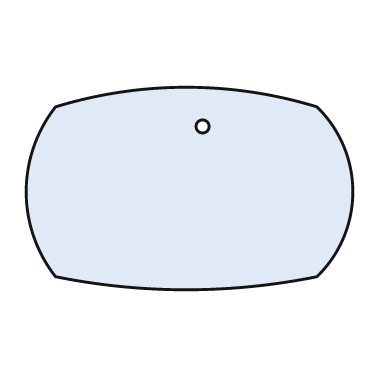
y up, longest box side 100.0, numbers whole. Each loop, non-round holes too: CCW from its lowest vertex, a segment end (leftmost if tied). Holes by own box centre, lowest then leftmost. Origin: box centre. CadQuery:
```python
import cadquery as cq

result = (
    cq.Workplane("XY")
    .moveTo(-41.0, -27.0)
    .threePointArc((-1.0, -31.0), (39.0, -27.0))
    .threePointArc((50.0, -1.0), (39.0, 25.0))
    .threePointArc((-1.0, 31.0), (-41.0, 25.0))
    .threePointArc((-50.0, -1.0), (-41.0, -27.0))
    .close()
    .moveTo(4.0, 19.0)
    .circle(2.0)
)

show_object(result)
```